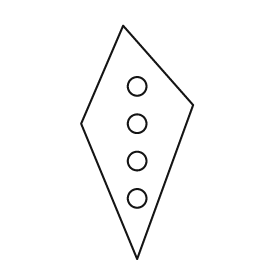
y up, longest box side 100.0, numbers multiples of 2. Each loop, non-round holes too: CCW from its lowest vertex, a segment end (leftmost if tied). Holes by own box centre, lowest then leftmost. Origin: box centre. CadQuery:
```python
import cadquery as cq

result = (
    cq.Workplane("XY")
    .moveTo(0.0, -50.0)
    .lineTo(24.0, 16.0)
    .lineTo(-6.0, 50.0)
    .lineTo(-24.0, 8.0)
    .close()
    .moveTo(0.0, -24.0)
    .circle(4.0)
    .moveTo(0.0, -8.0)
    .circle(4.0)
    .moveTo(0.0, 8.0)
    .circle(4.0)
    .moveTo(0.0, 24.0)
    .circle(4.0)
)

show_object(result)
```